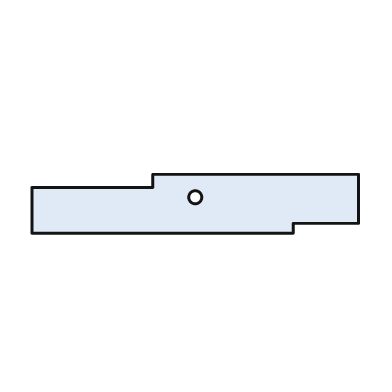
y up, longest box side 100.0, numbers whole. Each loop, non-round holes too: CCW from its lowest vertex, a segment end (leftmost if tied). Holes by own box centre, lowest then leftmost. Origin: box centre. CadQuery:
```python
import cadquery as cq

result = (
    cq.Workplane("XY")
    .moveTo(-50.0, -9.0)
    .lineTo(30.0, -9.0)
    .lineTo(30.0, -6.0)
    .lineTo(50.0, -6.0)
    .lineTo(50.0, 9.0)
    .lineTo(-13.0, 9.0)
    .lineTo(-13.0, 5.0)
    .lineTo(-50.0, 5.0)
    .close()
    .moveTo(0.0, 2.0)
    .circle(2.0)
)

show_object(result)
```